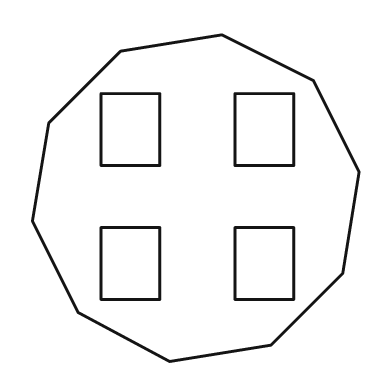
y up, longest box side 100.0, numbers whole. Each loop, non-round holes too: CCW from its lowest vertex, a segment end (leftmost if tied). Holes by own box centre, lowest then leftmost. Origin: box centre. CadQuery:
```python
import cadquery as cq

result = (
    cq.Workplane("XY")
    .moveTo(-8.0, -50.0)
    .lineTo(23.0, -45.0)
    .lineTo(45.0, -23.0)
    .lineTo(50.0, 8.0)
    .lineTo(36.0, 36.0)
    .lineTo(8.0, 50.0)
    .lineTo(-23.0, 45.0)
    .lineTo(-45.0, 23.0)
    .lineTo(-50.0, -7.0)
    .lineTo(-36.0, -35.0)
    .close()
    .moveTo(-29.0, -31.0)
    .lineTo(-11.0, -31.0)
    .lineTo(-11.0, -9.0)
    .lineTo(-29.0, -9.0)
    .close()
    .moveTo(12.0, -31.0)
    .lineTo(30.0, -31.0)
    .lineTo(30.0, -9.0)
    .lineTo(12.0, -9.0)
    .close()
    .moveTo(-29.0, 10.0)
    .lineTo(-11.0, 10.0)
    .lineTo(-11.0, 32.0)
    .lineTo(-29.0, 32.0)
    .close()
    .moveTo(12.0, 10.0)
    .lineTo(30.0, 10.0)
    .lineTo(30.0, 32.0)
    .lineTo(12.0, 32.0)
    .close()
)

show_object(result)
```